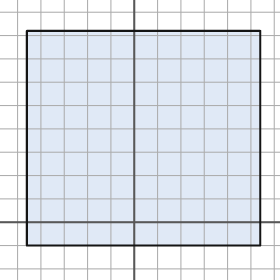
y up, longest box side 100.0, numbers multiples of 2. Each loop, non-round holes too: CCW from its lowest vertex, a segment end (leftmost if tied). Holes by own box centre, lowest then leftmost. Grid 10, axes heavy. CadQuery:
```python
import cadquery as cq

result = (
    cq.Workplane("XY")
    .moveTo(-46.0, -10.0)
    .lineTo(54.0, -10.0)
    .lineTo(54.0, 82.0)
    .lineTo(-46.0, 82.0)
    .close()
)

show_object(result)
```